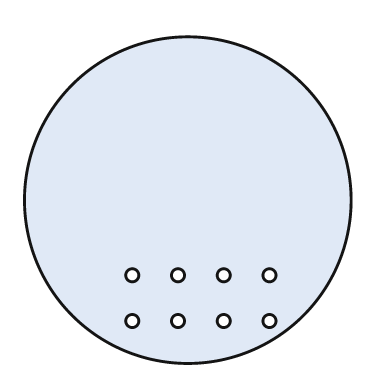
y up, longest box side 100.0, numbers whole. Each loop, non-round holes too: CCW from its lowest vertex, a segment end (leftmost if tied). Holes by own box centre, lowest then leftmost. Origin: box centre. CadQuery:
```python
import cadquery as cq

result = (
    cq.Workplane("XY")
    .moveTo(0.0, 0.0)
    .circle(50.0)
    .moveTo(-17.0, -37.0)
    .circle(2.0)
    .moveTo(-3.0, -37.0)
    .circle(2.0)
    .moveTo(11.0, -37.0)
    .circle(2.0)
    .moveTo(25.0, -37.0)
    .circle(2.0)
    .moveTo(-17.0, -23.0)
    .circle(2.0)
    .moveTo(-3.0, -23.0)
    .circle(2.0)
    .moveTo(11.0, -23.0)
    .circle(2.0)
    .moveTo(25.0, -23.0)
    .circle(2.0)
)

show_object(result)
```